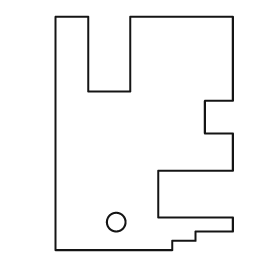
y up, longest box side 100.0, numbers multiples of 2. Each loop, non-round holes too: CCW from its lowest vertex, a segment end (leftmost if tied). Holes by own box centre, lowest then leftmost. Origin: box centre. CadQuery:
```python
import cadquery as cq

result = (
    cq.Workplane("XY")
    .moveTo(-38.0, -50.0)
    .lineTo(12.0, -50.0)
    .lineTo(12.0, -46.0)
    .lineTo(22.0, -46.0)
    .lineTo(22.0, -42.0)
    .lineTo(38.0, -42.0)
    .lineTo(38.0, -36.0)
    .lineTo(6.0, -36.0)
    .lineTo(6.0, -16.0)
    .lineTo(38.0, -16.0)
    .lineTo(38.0, 0.0)
    .lineTo(26.0, 0.0)
    .lineTo(26.0, 14.0)
    .lineTo(38.0, 14.0)
    .lineTo(38.0, 50.0)
    .lineTo(-6.0, 50.0)
    .lineTo(-6.0, 18.0)
    .lineTo(-24.0, 18.0)
    .lineTo(-24.0, 50.0)
    .lineTo(-38.0, 50.0)
    .close()
    .moveTo(-12.0, -38.0)
    .circle(4.0)
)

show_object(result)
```